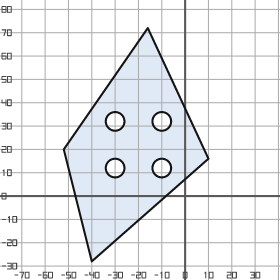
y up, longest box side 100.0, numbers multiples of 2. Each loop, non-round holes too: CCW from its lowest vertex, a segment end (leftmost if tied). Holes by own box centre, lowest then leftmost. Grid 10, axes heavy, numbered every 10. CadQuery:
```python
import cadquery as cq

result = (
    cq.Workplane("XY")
    .moveTo(-40.0, -28.0)
    .lineTo(10.0, 16.0)
    .lineTo(-16.0, 72.0)
    .lineTo(-52.0, 20.0)
    .close()
    .moveTo(-30.0, 12.0)
    .circle(4.0)
    .moveTo(-10.0, 12.0)
    .circle(4.0)
    .moveTo(-30.0, 32.0)
    .circle(4.0)
    .moveTo(-10.0, 32.0)
    .circle(4.0)
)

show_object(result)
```